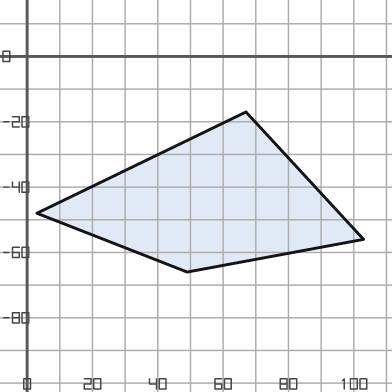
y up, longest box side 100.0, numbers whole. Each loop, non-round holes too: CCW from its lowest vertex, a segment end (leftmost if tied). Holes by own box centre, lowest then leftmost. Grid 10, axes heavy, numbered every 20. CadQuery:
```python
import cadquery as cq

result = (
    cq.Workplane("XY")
    .moveTo(49.0, -66.0)
    .lineTo(103.0, -56.0)
    .lineTo(67.0, -17.0)
    .lineTo(3.0, -48.0)
    .close()
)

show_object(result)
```